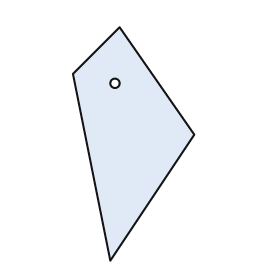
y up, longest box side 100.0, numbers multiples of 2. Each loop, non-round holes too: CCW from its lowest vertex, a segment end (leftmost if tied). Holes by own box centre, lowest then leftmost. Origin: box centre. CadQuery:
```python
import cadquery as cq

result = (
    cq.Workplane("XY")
    .moveTo(-10.0, -50.0)
    .lineTo(26.0, 4.0)
    .lineTo(-6.0, 50.0)
    .lineTo(-26.0, 30.0)
    .close()
    .moveTo(-8.0, 26.0)
    .circle(2.0)
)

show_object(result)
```